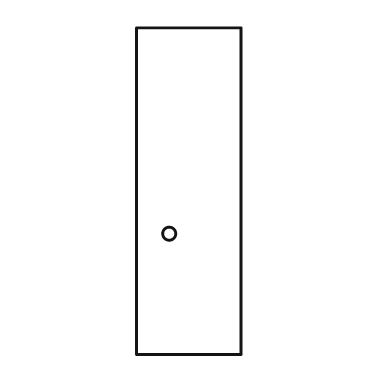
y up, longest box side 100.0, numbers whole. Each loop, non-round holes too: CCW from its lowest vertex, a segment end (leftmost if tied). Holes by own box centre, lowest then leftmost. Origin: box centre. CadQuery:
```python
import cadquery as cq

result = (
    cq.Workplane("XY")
    .moveTo(-16.0, -50.0)
    .lineTo(16.0, -50.0)
    .lineTo(16.0, 50.0)
    .lineTo(-16.0, 50.0)
    .close()
    .moveTo(-6.0, -13.0)
    .circle(2.0)
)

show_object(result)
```